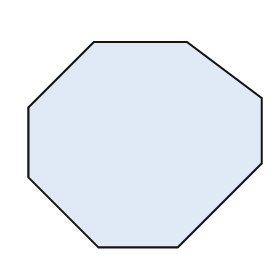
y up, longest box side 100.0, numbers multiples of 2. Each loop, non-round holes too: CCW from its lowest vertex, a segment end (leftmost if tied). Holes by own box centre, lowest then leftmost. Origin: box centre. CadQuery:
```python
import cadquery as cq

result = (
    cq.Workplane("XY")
    .moveTo(-20.0, -44.0)
    .lineTo(14.0, -44.0)
    .lineTo(50.0, -8.0)
    .lineTo(50.0, 20.0)
    .lineTo(18.0, 44.0)
    .lineTo(-22.0, 44.0)
    .lineTo(-50.0, 16.0)
    .lineTo(-50.0, -14.0)
    .close()
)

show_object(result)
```